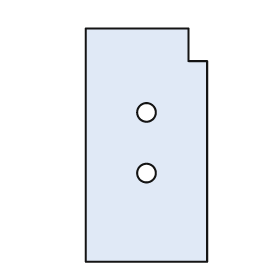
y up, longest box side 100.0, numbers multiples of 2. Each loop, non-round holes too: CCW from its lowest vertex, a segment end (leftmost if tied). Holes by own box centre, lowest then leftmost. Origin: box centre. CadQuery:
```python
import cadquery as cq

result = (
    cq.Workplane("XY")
    .moveTo(-26.0, -50.0)
    .lineTo(26.0, -50.0)
    .lineTo(26.0, 36.0)
    .lineTo(18.0, 36.0)
    .lineTo(18.0, 50.0)
    .lineTo(-26.0, 50.0)
    .close()
    .moveTo(0.0, -12.0)
    .circle(4.0)
    .moveTo(0.0, 14.0)
    .circle(4.0)
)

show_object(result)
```